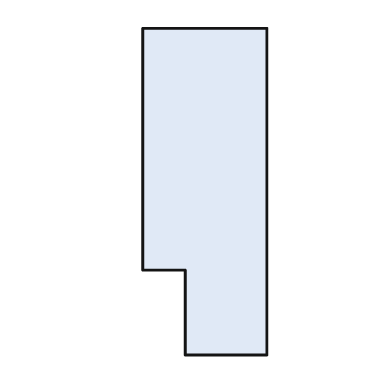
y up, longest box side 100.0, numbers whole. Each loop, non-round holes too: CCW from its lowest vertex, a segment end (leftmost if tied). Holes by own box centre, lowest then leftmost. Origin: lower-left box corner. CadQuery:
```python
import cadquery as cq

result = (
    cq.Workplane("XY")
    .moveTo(13.0, 0.0)
    .lineTo(38.0, 0.0)
    .lineTo(38.0, 100.0)
    .lineTo(0.0, 100.0)
    .lineTo(0.0, 26.0)
    .lineTo(13.0, 26.0)
    .close()
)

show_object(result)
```